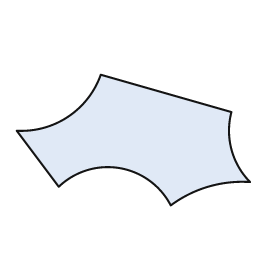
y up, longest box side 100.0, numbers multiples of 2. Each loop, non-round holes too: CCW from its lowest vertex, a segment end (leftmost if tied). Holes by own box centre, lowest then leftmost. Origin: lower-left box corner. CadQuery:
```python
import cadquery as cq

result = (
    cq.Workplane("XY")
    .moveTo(66.0, 0.0)
    .threePointArc((82.0, 8.0), (100.0, 10.0))
    .threePointArc((92.0, 24.0), (92.0, 40.0))
    .lineTo(36.0, 56.0)
    .threePointArc((22.0, 38.0), (0.0, 32.0))
    .lineTo(18.0, 8.0)
    .threePointArc((44.0, 16.0), (66.0, 0.0))
    .close()
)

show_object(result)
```